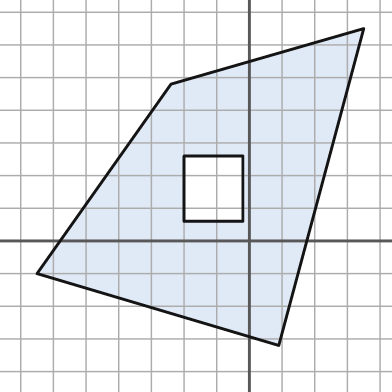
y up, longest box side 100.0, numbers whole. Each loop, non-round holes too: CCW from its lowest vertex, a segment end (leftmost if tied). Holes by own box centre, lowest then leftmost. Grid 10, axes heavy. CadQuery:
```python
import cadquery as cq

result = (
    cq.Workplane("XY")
    .moveTo(9.0, -32.0)
    .lineTo(35.0, 65.0)
    .lineTo(-24.0, 48.0)
    .lineTo(-65.0, -10.0)
    .close()
    .moveTo(-20.0, 6.0)
    .lineTo(-2.0, 6.0)
    .lineTo(-2.0, 26.0)
    .lineTo(-20.0, 26.0)
    .close()
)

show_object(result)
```